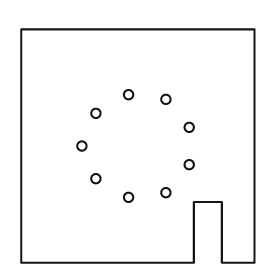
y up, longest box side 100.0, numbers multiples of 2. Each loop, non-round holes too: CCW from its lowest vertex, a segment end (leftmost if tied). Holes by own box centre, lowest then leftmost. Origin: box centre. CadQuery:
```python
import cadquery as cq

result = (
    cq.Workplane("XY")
    .moveTo(-50.0, -50.0)
    .lineTo(24.0, -50.0)
    .lineTo(24.0, -24.0)
    .lineTo(36.0, -24.0)
    .lineTo(36.0, -50.0)
    .lineTo(50.0, -50.0)
    .lineTo(50.0, 50.0)
    .lineTo(-50.0, 50.0)
    .close()
    .moveTo(-4.0, -22.0)
    .circle(2.0)
    .moveTo(12.0, -20.0)
    .circle(2.0)
    .moveTo(-18.0, -14.0)
    .circle(2.0)
    .moveTo(22.0, -8.0)
    .circle(2.0)
    .moveTo(-24.0, 0.0)
    .circle(2.0)
    .moveTo(22.0, 8.0)
    .circle(2.0)
    .moveTo(-18.0, 14.0)
    .circle(2.0)
    .moveTo(12.0, 20.0)
    .circle(2.0)
    .moveTo(-4.0, 22.0)
    .circle(2.0)
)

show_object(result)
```